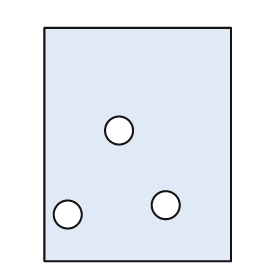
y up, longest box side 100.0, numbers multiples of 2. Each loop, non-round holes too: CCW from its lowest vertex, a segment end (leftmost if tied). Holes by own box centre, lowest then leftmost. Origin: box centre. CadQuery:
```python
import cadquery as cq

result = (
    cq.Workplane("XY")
    .moveTo(-40.0, -50.0)
    .lineTo(40.0, -50.0)
    .lineTo(40.0, 50.0)
    .lineTo(-40.0, 50.0)
    .close()
    .moveTo(-30.0, -30.0)
    .circle(6.0)
    .moveTo(12.0, -26.0)
    .circle(6.0)
    .moveTo(-8.0, 6.0)
    .circle(6.0)
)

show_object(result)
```